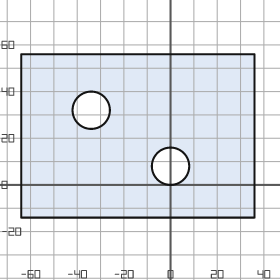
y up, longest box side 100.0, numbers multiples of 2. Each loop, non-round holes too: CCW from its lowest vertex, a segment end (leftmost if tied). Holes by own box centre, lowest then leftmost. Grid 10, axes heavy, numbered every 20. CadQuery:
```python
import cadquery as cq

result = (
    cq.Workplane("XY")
    .moveTo(-64.0, -14.0)
    .lineTo(36.0, -14.0)
    .lineTo(36.0, 56.0)
    .lineTo(-64.0, 56.0)
    .close()
    .moveTo(0.0, 8.0)
    .circle(8.0)
    .moveTo(-34.0, 32.0)
    .circle(8.0)
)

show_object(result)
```